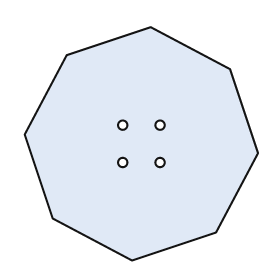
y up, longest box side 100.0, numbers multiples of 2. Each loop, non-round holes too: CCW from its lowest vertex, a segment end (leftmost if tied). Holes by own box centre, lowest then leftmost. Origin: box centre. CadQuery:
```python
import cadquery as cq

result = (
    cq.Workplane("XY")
    .moveTo(-4.0, -50.0)
    .lineTo(32.0, -38.0)
    .lineTo(50.0, -4.0)
    .lineTo(38.0, 32.0)
    .lineTo(4.0, 50.0)
    .lineTo(-32.0, 38.0)
    .lineTo(-50.0, 4.0)
    .lineTo(-38.0, -32.0)
    .close()
    .moveTo(-8.0, -8.0)
    .circle(2.0)
    .moveTo(8.0, -8.0)
    .circle(2.0)
    .moveTo(-8.0, 8.0)
    .circle(2.0)
    .moveTo(8.0, 8.0)
    .circle(2.0)
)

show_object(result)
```